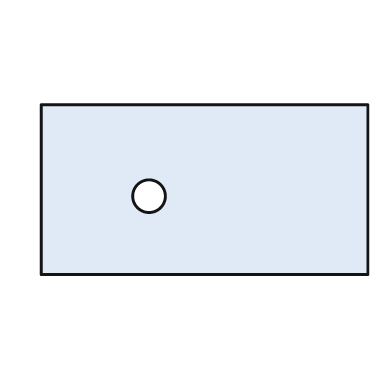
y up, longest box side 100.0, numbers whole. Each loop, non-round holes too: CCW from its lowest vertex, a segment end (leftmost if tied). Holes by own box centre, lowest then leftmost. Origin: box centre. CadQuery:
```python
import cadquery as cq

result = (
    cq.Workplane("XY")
    .moveTo(-50.0, -26.0)
    .lineTo(50.0, -26.0)
    .lineTo(50.0, 26.0)
    .lineTo(-50.0, 26.0)
    .close()
    .moveTo(-17.0, -2.0)
    .circle(5.0)
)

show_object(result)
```